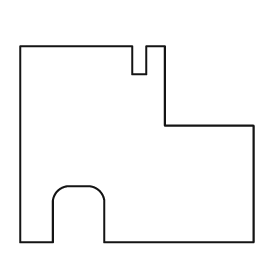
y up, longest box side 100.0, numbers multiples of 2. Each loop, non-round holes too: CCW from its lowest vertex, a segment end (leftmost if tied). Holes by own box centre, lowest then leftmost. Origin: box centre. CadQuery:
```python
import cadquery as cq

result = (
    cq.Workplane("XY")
    .moveTo(-50.0, -42.0)
    .lineTo(-36.0, -42.0)
    .lineTo(-36.0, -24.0)
    .threePointArc((-34.0, -20.0), (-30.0, -18.0))
    .lineTo(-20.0, -18.0)
    .threePointArc((-16.0, -20.0), (-14.0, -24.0))
    .lineTo(-14.0, -42.0)
    .lineTo(50.0, -42.0)
    .lineTo(50.0, 8.0)
    .lineTo(12.0, 8.0)
    .lineTo(12.0, 42.0)
    .lineTo(4.0, 42.0)
    .lineTo(4.0, 30.0)
    .lineTo(-2.0, 30.0)
    .lineTo(-2.0, 42.0)
    .lineTo(-50.0, 42.0)
    .close()
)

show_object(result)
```